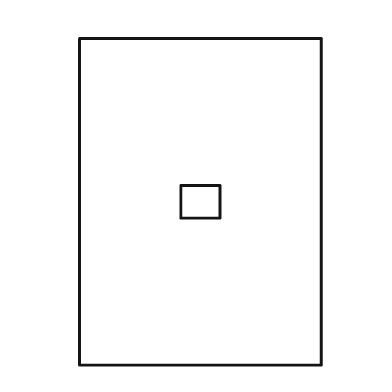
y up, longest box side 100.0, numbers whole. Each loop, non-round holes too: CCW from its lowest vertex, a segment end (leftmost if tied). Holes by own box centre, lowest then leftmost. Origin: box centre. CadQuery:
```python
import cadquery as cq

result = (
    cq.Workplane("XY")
    .moveTo(-37.0, -50.0)
    .lineTo(37.0, -50.0)
    .lineTo(37.0, 50.0)
    .lineTo(-37.0, 50.0)
    .close()
    .moveTo(-6.0, -5.0)
    .lineTo(6.0, -5.0)
    .lineTo(6.0, 5.0)
    .lineTo(-6.0, 5.0)
    .close()
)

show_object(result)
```